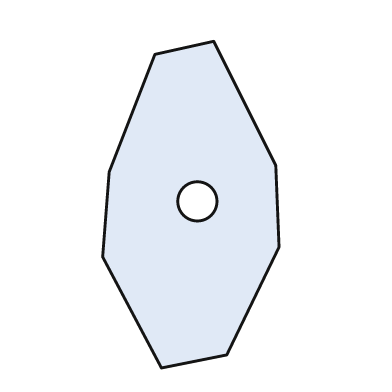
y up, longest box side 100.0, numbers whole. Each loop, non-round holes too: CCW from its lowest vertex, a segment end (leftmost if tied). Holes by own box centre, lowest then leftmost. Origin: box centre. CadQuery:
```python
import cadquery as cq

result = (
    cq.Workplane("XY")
    .moveTo(-9.0, -50.0)
    .lineTo(11.0, -46.0)
    .lineTo(27.0, -13.0)
    .lineTo(26.0, 12.0)
    .lineTo(7.0, 50.0)
    .lineTo(-11.0, 46.0)
    .lineTo(-25.0, 10.0)
    .lineTo(-27.0, -16.0)
    .close()
    .moveTo(2.0, 1.0)
    .circle(6.0)
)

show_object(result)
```